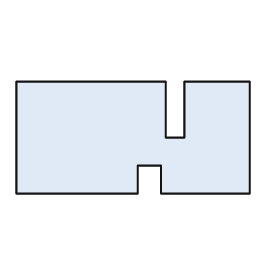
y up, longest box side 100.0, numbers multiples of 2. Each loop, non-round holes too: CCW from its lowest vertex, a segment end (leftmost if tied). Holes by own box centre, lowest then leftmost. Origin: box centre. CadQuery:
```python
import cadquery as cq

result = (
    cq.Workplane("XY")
    .moveTo(-50.0, -24.0)
    .lineTo(2.0, -24.0)
    .lineTo(2.0, -12.0)
    .lineTo(12.0, -12.0)
    .lineTo(12.0, -24.0)
    .lineTo(50.0, -24.0)
    .lineTo(50.0, 24.0)
    .lineTo(22.0, 24.0)
    .lineTo(22.0, 0.0)
    .lineTo(14.0, 0.0)
    .lineTo(14.0, 24.0)
    .lineTo(-50.0, 24.0)
    .close()
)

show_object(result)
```